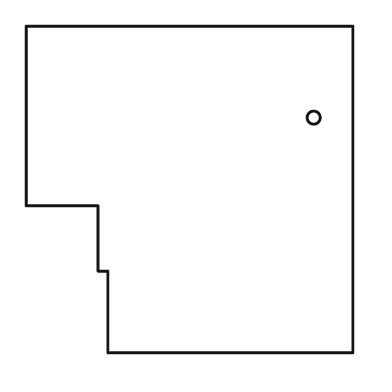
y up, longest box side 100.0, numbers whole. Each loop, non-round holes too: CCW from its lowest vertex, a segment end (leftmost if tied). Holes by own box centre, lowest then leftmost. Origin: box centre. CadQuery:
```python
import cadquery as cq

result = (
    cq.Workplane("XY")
    .moveTo(-25.0, -50.0)
    .lineTo(50.0, -50.0)
    .lineTo(50.0, 50.0)
    .lineTo(-50.0, 50.0)
    .lineTo(-50.0, -5.0)
    .lineTo(-28.0, -5.0)
    .lineTo(-28.0, -25.0)
    .lineTo(-25.0, -25.0)
    .close()
    .moveTo(38.0, 22.0)
    .circle(2.0)
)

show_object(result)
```